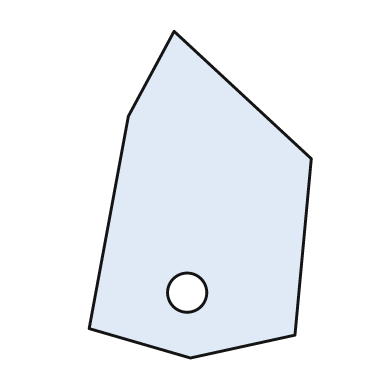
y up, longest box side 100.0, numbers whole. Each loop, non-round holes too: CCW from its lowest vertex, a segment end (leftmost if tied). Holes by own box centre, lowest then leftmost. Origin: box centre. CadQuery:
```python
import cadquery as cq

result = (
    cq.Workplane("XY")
    .moveTo(-3.0, -50.0)
    .lineTo(29.0, -43.0)
    .lineTo(34.0, 11.0)
    .lineTo(-8.0, 50.0)
    .lineTo(-22.0, 24.0)
    .lineTo(-34.0, -41.0)
    .close()
    .moveTo(-4.0, -30.0)
    .circle(6.0)
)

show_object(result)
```